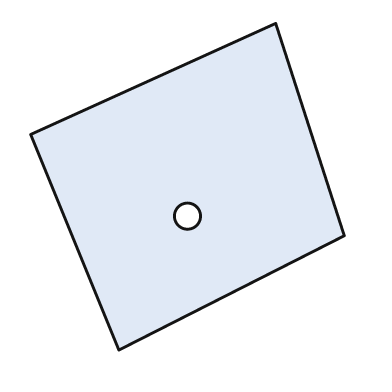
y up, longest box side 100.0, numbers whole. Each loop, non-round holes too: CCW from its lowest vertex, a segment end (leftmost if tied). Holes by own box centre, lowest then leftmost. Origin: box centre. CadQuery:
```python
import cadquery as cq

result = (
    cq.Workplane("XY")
    .moveTo(-21.0, -50.0)
    .lineTo(48.0, -15.0)
    .lineTo(27.0, 50.0)
    .lineTo(-48.0, 16.0)
    .close()
    .moveTo(0.0, -9.0)
    .circle(4.0)
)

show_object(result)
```